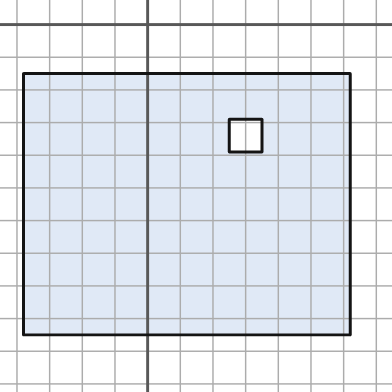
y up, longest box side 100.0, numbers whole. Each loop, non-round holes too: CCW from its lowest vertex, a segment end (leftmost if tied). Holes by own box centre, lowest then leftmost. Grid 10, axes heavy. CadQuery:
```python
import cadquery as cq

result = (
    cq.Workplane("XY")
    .moveTo(-38.0, -95.0)
    .lineTo(62.0, -95.0)
    .lineTo(62.0, -15.0)
    .lineTo(-38.0, -15.0)
    .close()
    .moveTo(25.0, -39.0)
    .lineTo(35.0, -39.0)
    .lineTo(35.0, -29.0)
    .lineTo(25.0, -29.0)
    .close()
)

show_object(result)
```